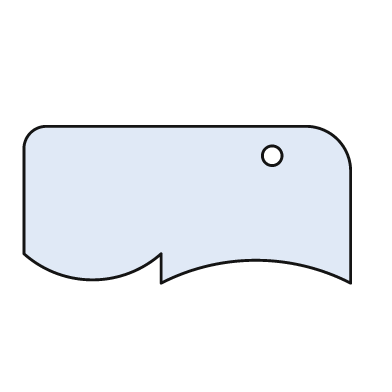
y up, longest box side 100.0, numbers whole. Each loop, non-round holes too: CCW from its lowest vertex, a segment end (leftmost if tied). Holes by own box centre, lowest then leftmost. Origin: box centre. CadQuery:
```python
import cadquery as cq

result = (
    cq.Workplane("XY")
    .moveTo(-8.0, -24.0)
    .threePointArc((21.0, -17.0), (50.0, -24.0))
    .lineTo(50.0, 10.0)
    .threePointArc((46.0, 20.0), (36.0, 24.0))
    .lineTo(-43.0, 24.0)
    .threePointArc((-48.0, 22.0), (-50.0, 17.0))
    .lineTo(-50.0, -15.0)
    .threePointArc((-29.0, -23.0), (-8.0, -15.0))
    .close()
    .moveTo(26.0, 15.0)
    .circle(3.0)
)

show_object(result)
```